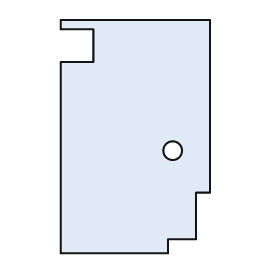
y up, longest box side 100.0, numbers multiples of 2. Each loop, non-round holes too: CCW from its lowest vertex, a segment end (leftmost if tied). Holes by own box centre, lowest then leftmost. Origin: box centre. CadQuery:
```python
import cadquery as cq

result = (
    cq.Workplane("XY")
    .moveTo(-32.0, -50.0)
    .lineTo(14.0, -50.0)
    .lineTo(14.0, -44.0)
    .lineTo(26.0, -44.0)
    .lineTo(26.0, -24.0)
    .lineTo(32.0, -24.0)
    .lineTo(32.0, 50.0)
    .lineTo(-32.0, 50.0)
    .lineTo(-32.0, 46.0)
    .lineTo(-18.0, 46.0)
    .lineTo(-18.0, 32.0)
    .lineTo(-32.0, 32.0)
    .close()
    .moveTo(16.0, -6.0)
    .circle(4.0)
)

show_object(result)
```